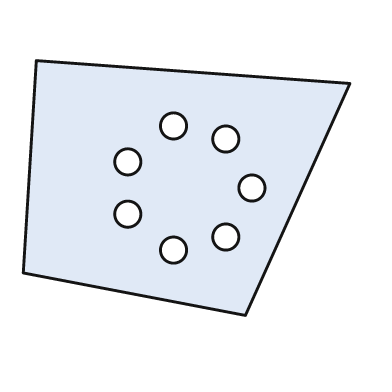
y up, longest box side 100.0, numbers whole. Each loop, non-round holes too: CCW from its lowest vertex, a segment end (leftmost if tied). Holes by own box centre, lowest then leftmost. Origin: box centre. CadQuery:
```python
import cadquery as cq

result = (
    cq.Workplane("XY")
    .moveTo(18.0, -39.0)
    .lineTo(50.0, 32.0)
    .lineTo(-46.0, 39.0)
    .lineTo(-50.0, -26.0)
    .close()
    .moveTo(-4.0, -19.0)
    .circle(4.0)
    .moveTo(12.0, -15.0)
    .circle(4.0)
    .moveTo(-18.0, -8.0)
    .circle(4.0)
    .moveTo(20.0, 0.0)
    .circle(4.0)
    .moveTo(-18.0, 8.0)
    .circle(4.0)
    .moveTo(12.0, 15.0)
    .circle(4.0)
    .moveTo(-4.0, 19.0)
    .circle(4.0)
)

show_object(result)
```